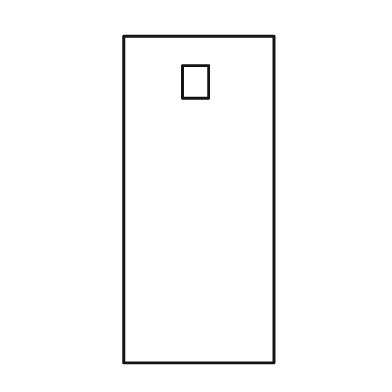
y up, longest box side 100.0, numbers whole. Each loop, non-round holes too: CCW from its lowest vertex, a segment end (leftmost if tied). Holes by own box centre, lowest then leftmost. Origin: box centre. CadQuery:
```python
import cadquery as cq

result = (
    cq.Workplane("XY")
    .moveTo(-23.0, -50.0)
    .lineTo(23.0, -50.0)
    .lineTo(23.0, 50.0)
    .lineTo(-23.0, 50.0)
    .close()
    .moveTo(-5.0, 31.0)
    .lineTo(3.0, 31.0)
    .lineTo(3.0, 41.0)
    .lineTo(-5.0, 41.0)
    .close()
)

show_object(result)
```